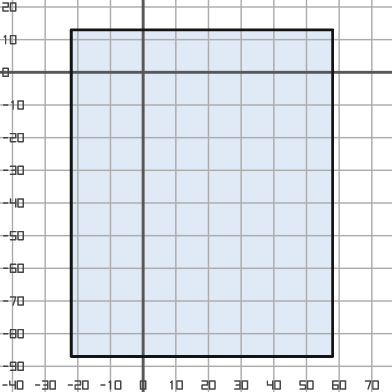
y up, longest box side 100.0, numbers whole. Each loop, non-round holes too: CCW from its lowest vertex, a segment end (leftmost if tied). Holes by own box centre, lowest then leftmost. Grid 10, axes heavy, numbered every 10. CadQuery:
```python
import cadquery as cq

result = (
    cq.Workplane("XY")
    .moveTo(-22.0, -87.0)
    .lineTo(58.0, -87.0)
    .lineTo(58.0, 13.0)
    .lineTo(-22.0, 13.0)
    .close()
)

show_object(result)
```